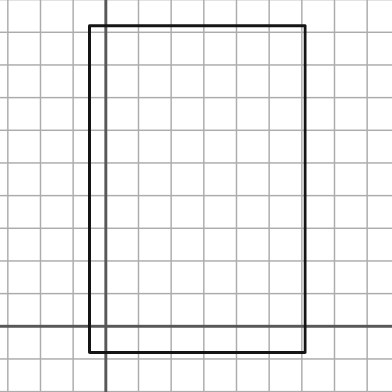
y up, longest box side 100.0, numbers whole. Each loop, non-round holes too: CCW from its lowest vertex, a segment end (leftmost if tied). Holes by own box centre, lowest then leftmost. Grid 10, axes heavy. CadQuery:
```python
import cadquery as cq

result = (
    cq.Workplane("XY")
    .moveTo(-5.0, -8.0)
    .lineTo(61.0, -8.0)
    .lineTo(61.0, 92.0)
    .lineTo(-5.0, 92.0)
    .close()
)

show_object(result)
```